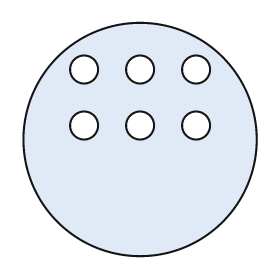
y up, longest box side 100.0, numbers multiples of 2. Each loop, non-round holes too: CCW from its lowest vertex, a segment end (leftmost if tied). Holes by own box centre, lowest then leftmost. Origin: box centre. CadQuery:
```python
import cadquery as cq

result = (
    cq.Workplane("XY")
    .moveTo(0.0, 0.0)
    .circle(50.0)
    .moveTo(-24.0, 6.0)
    .circle(6.0)
    .moveTo(0.0, 6.0)
    .circle(6.0)
    .moveTo(24.0, 6.0)
    .circle(6.0)
    .moveTo(-24.0, 30.0)
    .circle(6.0)
    .moveTo(0.0, 30.0)
    .circle(6.0)
    .moveTo(24.0, 30.0)
    .circle(6.0)
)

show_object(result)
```